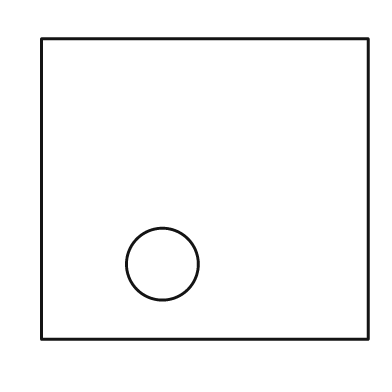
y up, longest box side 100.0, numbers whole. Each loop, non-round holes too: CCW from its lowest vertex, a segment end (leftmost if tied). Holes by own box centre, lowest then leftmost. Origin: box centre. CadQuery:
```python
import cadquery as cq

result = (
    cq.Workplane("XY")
    .moveTo(-50.0, -46.0)
    .lineTo(50.0, -46.0)
    .lineTo(50.0, 46.0)
    .lineTo(-50.0, 46.0)
    .close()
    .moveTo(-13.0, -23.0)
    .circle(11.0)
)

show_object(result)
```